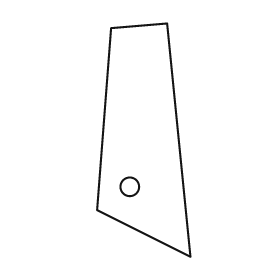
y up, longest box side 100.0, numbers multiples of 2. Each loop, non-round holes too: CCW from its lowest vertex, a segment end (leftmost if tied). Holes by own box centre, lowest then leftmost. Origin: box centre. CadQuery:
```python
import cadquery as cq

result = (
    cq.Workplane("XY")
    .moveTo(20.0, -50.0)
    .lineTo(10.0, 50.0)
    .lineTo(-14.0, 48.0)
    .lineTo(-20.0, -30.0)
    .close()
    .moveTo(-6.0, -20.0)
    .circle(4.0)
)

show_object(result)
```